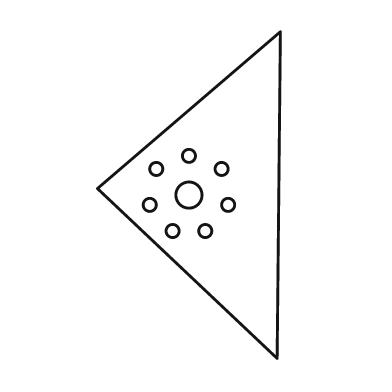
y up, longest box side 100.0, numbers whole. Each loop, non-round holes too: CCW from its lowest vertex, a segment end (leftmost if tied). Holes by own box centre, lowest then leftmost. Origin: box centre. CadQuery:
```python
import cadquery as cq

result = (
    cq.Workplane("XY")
    .moveTo(27.0, -50.0)
    .lineTo(28.0, 50.0)
    .lineTo(-28.0, 2.0)
    .close()
    .moveTo(-5.0, -11.0)
    .circle(2.0)
    .moveTo(5.0, -11.0)
    .circle(2.0)
    .moveTo(-12.0, -3.0)
    .circle(2.0)
    .moveTo(12.0, -3.0)
    .circle(2.0)
    .moveTo(0.0, 0.0)
    .circle(4.0)
    .moveTo(-10.0, 8.0)
    .circle(2.0)
    .moveTo(10.0, 8.0)
    .circle(2.0)
    .moveTo(0.0, 12.0)
    .circle(2.0)
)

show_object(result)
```